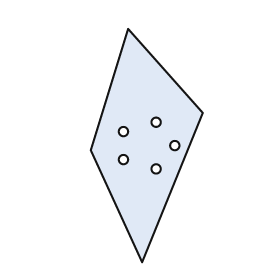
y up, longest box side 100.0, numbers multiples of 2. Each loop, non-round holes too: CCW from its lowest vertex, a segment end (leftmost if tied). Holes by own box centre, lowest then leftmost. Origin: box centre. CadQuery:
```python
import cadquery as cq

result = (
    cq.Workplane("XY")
    .moveTo(-2.0, -50.0)
    .lineTo(24.0, 14.0)
    .lineTo(-8.0, 50.0)
    .lineTo(-24.0, -2.0)
    .close()
    .moveTo(4.0, -10.0)
    .circle(2.0)
    .moveTo(-10.0, -6.0)
    .circle(2.0)
    .moveTo(12.0, 0.0)
    .circle(2.0)
    .moveTo(-10.0, 6.0)
    .circle(2.0)
    .moveTo(4.0, 10.0)
    .circle(2.0)
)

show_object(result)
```